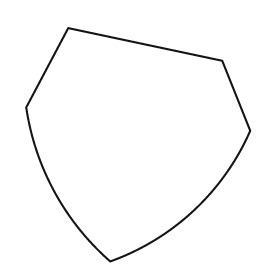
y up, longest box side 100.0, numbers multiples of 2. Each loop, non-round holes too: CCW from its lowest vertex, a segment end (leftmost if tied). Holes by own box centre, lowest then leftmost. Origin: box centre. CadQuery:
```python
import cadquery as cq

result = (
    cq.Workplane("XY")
    .moveTo(-12.0, -50.0)
    .threePointArc((24.0, -28.0), (48.0, 6.0))
    .lineTo(36.0, 36.0)
    .lineTo(-30.0, 50.0)
    .lineTo(-48.0, 16.0)
    .threePointArc((-36.0, -20.0), (-12.0, -50.0))
    .close()
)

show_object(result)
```